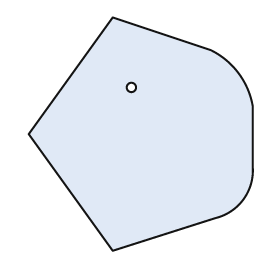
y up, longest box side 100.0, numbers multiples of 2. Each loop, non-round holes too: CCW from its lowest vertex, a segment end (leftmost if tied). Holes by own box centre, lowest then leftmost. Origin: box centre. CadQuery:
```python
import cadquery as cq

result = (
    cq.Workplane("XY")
    .moveTo(-12.0, -50.0)
    .lineTo(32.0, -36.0)
    .threePointArc((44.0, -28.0), (48.0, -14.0))
    .lineTo(48.0, 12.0)
    .threePointArc((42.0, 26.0), (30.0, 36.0))
    .lineTo(-12.0, 50.0)
    .lineTo(-48.0, 0.0)
    .close()
    .moveTo(-4.0, 20.0)
    .circle(2.0)
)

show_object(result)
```